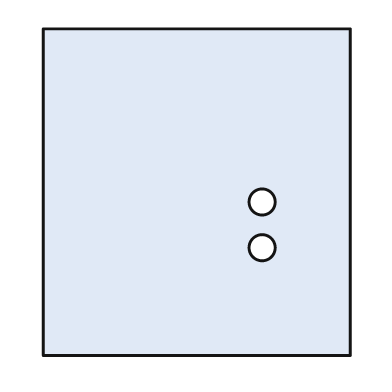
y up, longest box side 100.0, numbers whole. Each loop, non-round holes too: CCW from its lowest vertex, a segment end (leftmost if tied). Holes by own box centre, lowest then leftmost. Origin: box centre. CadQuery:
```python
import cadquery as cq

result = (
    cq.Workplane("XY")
    .moveTo(-47.0, -50.0)
    .lineTo(47.0, -50.0)
    .lineTo(47.0, 50.0)
    .lineTo(-47.0, 50.0)
    .close()
    .moveTo(20.0, -17.0)
    .circle(4.0)
    .moveTo(20.0, -3.0)
    .circle(4.0)
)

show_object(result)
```